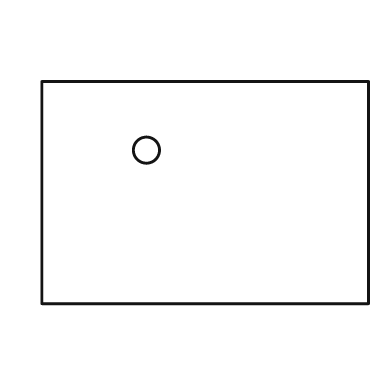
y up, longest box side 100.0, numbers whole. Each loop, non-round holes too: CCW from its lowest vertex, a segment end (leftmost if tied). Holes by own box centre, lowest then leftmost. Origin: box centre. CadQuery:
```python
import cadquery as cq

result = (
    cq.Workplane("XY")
    .moveTo(-50.0, -34.0)
    .lineTo(50.0, -34.0)
    .lineTo(50.0, 34.0)
    .lineTo(-50.0, 34.0)
    .close()
    .moveTo(-18.0, 13.0)
    .circle(4.0)
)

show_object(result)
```